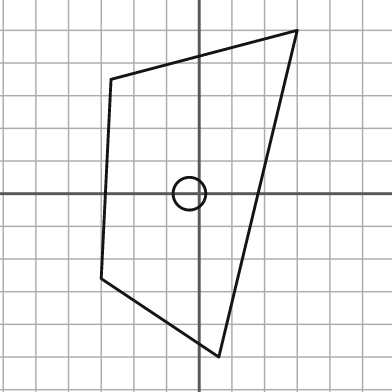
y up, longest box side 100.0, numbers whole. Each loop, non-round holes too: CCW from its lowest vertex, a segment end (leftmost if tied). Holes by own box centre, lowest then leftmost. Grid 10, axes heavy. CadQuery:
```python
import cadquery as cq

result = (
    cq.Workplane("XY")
    .moveTo(6.0, -50.0)
    .lineTo(30.0, 50.0)
    .lineTo(-27.0, 35.0)
    .lineTo(-30.0, -26.0)
    .close()
    .moveTo(-3.0, 0.0)
    .circle(5.0)
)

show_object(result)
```